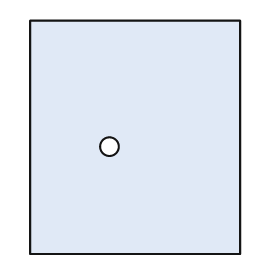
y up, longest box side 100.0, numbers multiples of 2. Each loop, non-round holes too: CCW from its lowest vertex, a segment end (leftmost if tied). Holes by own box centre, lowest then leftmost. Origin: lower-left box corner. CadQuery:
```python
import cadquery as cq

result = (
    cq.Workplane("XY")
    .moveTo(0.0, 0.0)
    .lineTo(90.0, 0.0)
    .lineTo(90.0, 100.0)
    .lineTo(0.0, 100.0)
    .close()
    .moveTo(34.0, 46.0)
    .circle(4.0)
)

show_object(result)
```